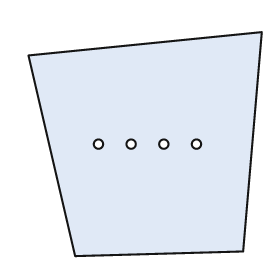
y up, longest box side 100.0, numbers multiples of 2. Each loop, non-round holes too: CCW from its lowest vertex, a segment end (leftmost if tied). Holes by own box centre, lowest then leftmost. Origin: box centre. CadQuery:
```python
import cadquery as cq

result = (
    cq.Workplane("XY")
    .moveTo(-30.0, -48.0)
    .lineTo(42.0, -46.0)
    .lineTo(50.0, 48.0)
    .lineTo(-50.0, 38.0)
    .close()
    .moveTo(-20.0, 0.0)
    .circle(2.0)
    .moveTo(-6.0, 0.0)
    .circle(2.0)
    .moveTo(8.0, 0.0)
    .circle(2.0)
    .moveTo(22.0, 0.0)
    .circle(2.0)
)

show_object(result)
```